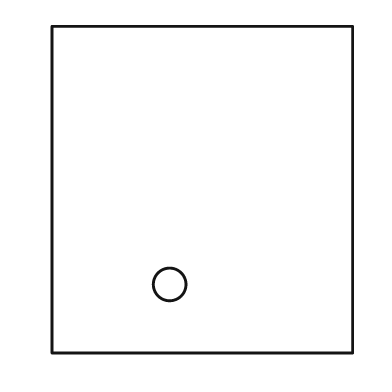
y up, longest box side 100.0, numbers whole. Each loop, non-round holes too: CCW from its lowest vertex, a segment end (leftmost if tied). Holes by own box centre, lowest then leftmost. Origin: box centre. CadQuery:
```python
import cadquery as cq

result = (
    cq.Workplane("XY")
    .moveTo(-46.0, -50.0)
    .lineTo(46.0, -50.0)
    .lineTo(46.0, 50.0)
    .lineTo(-46.0, 50.0)
    .close()
    .moveTo(-10.0, -29.0)
    .circle(5.0)
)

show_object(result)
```